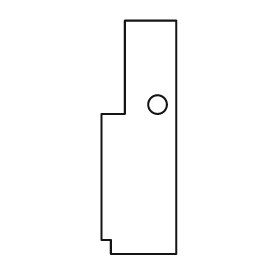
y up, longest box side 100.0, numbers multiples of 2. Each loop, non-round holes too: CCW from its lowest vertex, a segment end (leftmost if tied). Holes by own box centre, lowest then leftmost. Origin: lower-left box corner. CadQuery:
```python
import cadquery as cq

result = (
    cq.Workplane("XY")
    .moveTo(4.0, 0.0)
    .lineTo(32.0, 0.0)
    .lineTo(32.0, 100.0)
    .lineTo(10.0, 100.0)
    .lineTo(10.0, 60.0)
    .lineTo(0.0, 60.0)
    .lineTo(0.0, 6.0)
    .lineTo(4.0, 6.0)
    .close()
    .moveTo(24.0, 64.0)
    .circle(4.0)
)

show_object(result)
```